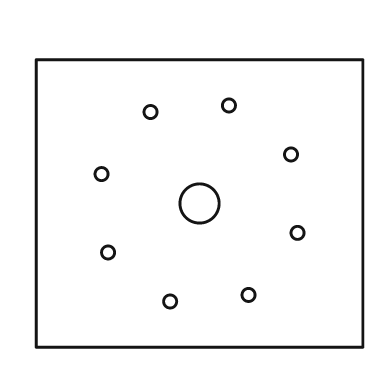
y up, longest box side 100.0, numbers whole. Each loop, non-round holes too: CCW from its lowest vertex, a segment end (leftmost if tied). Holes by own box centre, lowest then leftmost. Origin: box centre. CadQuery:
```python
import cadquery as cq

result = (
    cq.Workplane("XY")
    .moveTo(-50.0, -44.0)
    .lineTo(50.0, -44.0)
    .lineTo(50.0, 44.0)
    .lineTo(-50.0, 44.0)
    .close()
    .moveTo(-9.0, -30.0)
    .circle(2.0)
    .moveTo(15.0, -28.0)
    .circle(2.0)
    .moveTo(-28.0, -15.0)
    .circle(2.0)
    .moveTo(30.0, -9.0)
    .circle(2.0)
    .moveTo(0.0, 0.0)
    .circle(6.0)
    .moveTo(-30.0, 9.0)
    .circle(2.0)
    .moveTo(28.0, 15.0)
    .circle(2.0)
    .moveTo(-15.0, 28.0)
    .circle(2.0)
    .moveTo(9.0, 30.0)
    .circle(2.0)
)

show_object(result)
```